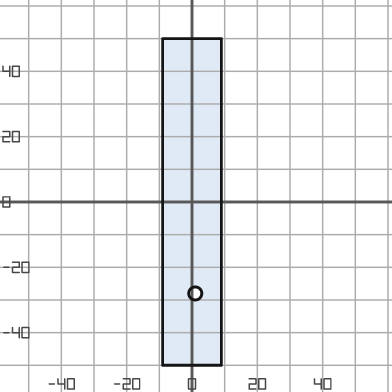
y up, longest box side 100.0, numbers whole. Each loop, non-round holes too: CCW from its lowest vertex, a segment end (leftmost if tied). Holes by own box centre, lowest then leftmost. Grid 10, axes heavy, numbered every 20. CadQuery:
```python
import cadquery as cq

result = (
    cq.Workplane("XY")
    .moveTo(-9.0, -50.0)
    .lineTo(9.0, -50.0)
    .lineTo(9.0, 50.0)
    .lineTo(-9.0, 50.0)
    .close()
    .moveTo(1.0, -28.0)
    .circle(2.0)
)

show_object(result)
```